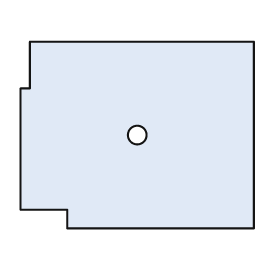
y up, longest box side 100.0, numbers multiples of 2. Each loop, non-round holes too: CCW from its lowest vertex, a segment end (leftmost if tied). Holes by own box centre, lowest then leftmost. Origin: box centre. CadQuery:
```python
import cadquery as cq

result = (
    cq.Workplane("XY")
    .moveTo(-30.0, -40.0)
    .lineTo(50.0, -40.0)
    .lineTo(50.0, 40.0)
    .lineTo(-46.0, 40.0)
    .lineTo(-46.0, 20.0)
    .lineTo(-50.0, 20.0)
    .lineTo(-50.0, -32.0)
    .lineTo(-30.0, -32.0)
    .close()
    .moveTo(0.0, 0.0)
    .circle(4.0)
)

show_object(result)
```